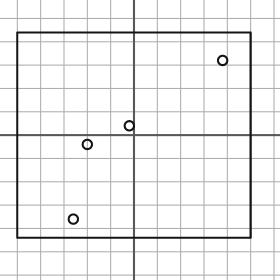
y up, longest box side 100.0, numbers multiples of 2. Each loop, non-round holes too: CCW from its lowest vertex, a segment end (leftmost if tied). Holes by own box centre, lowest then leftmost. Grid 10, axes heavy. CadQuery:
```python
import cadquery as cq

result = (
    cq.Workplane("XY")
    .moveTo(-50.0, -44.0)
    .lineTo(50.0, -44.0)
    .lineTo(50.0, 44.0)
    .lineTo(-50.0, 44.0)
    .close()
    .moveTo(-26.0, -36.0)
    .circle(2.0)
    .moveTo(-20.0, -4.0)
    .circle(2.0)
    .moveTo(-2.0, 4.0)
    .circle(2.0)
    .moveTo(38.0, 32.0)
    .circle(2.0)
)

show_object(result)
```